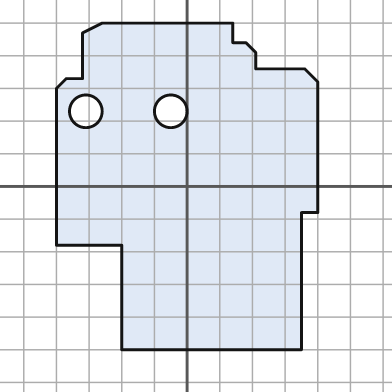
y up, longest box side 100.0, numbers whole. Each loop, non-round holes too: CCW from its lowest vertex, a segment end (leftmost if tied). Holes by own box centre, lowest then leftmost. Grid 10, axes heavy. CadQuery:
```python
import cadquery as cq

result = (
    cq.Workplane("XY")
    .moveTo(-20.0, -50.0)
    .lineTo(35.0, -50.0)
    .lineTo(35.0, -8.0)
    .lineTo(40.0, -8.0)
    .lineTo(40.0, 32.0)
    .lineTo(36.0, 36.0)
    .lineTo(21.0, 36.0)
    .lineTo(21.0, 41.0)
    .lineTo(18.0, 44.0)
    .lineTo(14.0, 44.0)
    .lineTo(14.0, 50.0)
    .lineTo(-26.0, 50.0)
    .lineTo(-32.0, 47.0)
    .lineTo(-32.0, 33.0)
    .lineTo(-37.0, 33.0)
    .lineTo(-40.0, 30.0)
    .lineTo(-40.0, -18.0)
    .lineTo(-20.0, -18.0)
    .close()
    .moveTo(-31.0, 23.0)
    .circle(5.0)
    .moveTo(-5.0, 23.0)
    .circle(5.0)
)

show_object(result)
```